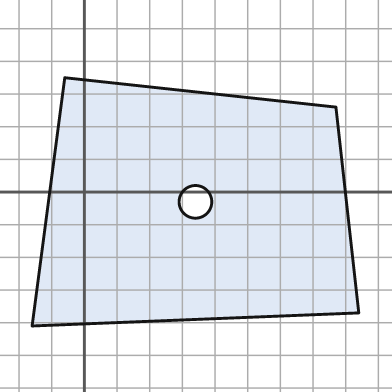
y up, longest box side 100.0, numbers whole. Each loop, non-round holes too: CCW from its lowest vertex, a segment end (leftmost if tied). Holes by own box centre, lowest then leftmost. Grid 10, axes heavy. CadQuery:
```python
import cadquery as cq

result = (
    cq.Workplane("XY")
    .moveTo(-16.0, -41.0)
    .lineTo(84.0, -37.0)
    .lineTo(77.0, 26.0)
    .lineTo(-6.0, 35.0)
    .close()
    .moveTo(34.0, -3.0)
    .circle(5.0)
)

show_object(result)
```